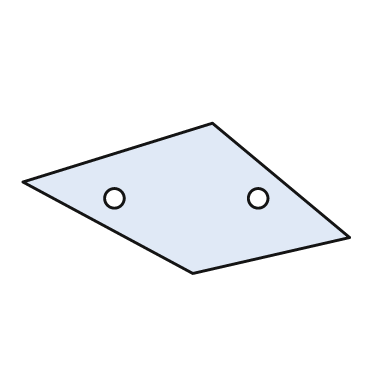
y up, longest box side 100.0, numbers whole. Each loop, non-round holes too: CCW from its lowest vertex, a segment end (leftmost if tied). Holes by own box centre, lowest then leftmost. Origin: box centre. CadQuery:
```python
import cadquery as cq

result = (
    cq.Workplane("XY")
    .moveTo(2.0, -23.0)
    .lineTo(50.0, -12.0)
    .lineTo(8.0, 23.0)
    .lineTo(-50.0, 5.0)
    .close()
    .moveTo(-22.0, 0.0)
    .circle(3.0)
    .moveTo(22.0, 0.0)
    .circle(3.0)
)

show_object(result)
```